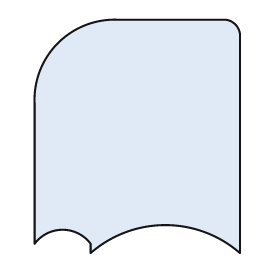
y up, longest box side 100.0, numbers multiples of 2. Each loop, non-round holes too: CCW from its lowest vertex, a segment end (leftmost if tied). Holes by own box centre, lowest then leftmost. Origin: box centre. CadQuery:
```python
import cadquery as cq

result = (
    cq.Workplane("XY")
    .moveTo(-20.0, -50.0)
    .threePointArc((12.0, -38.0), (44.0, -50.0))
    .lineTo(44.0, 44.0)
    .threePointArc((42.0, 48.0), (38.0, 50.0))
    .lineTo(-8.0, 50.0)
    .threePointArc((-34.0, 40.0), (-44.0, 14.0))
    .lineTo(-44.0, -46.0)
    .threePointArc((-32.0, -40.0), (-20.0, -46.0))
    .close()
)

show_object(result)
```